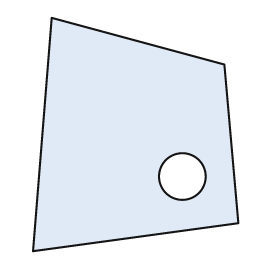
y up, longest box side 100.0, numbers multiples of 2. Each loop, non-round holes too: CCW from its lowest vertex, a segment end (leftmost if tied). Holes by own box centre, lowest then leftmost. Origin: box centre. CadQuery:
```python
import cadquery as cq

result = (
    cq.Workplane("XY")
    .moveTo(-44.0, -50.0)
    .lineTo(44.0, -38.0)
    .lineTo(38.0, 30.0)
    .lineTo(-36.0, 50.0)
    .close()
    .moveTo(20.0, -18.0)
    .circle(10.0)
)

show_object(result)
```